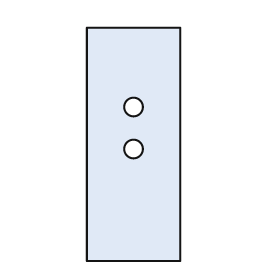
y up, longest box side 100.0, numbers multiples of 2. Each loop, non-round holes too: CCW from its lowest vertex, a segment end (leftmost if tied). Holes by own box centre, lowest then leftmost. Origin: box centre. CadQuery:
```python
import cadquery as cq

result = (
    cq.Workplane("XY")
    .moveTo(-20.0, -50.0)
    .lineTo(20.0, -50.0)
    .lineTo(20.0, 50.0)
    .lineTo(-20.0, 50.0)
    .close()
    .moveTo(0.0, -2.0)
    .circle(4.0)
    .moveTo(0.0, 16.0)
    .circle(4.0)
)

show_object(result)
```